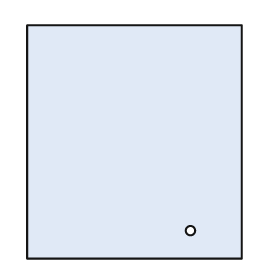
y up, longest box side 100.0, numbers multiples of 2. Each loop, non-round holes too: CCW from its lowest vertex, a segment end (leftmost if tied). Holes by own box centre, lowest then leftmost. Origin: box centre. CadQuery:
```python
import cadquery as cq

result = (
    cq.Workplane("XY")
    .moveTo(-46.0, -50.0)
    .lineTo(46.0, -50.0)
    .lineTo(46.0, 50.0)
    .lineTo(-46.0, 50.0)
    .close()
    .moveTo(24.0, -38.0)
    .circle(2.0)
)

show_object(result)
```